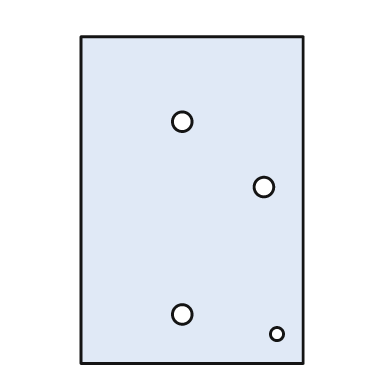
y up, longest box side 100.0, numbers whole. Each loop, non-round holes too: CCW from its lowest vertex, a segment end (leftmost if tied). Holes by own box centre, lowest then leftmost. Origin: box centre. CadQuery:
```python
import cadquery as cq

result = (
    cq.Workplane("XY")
    .moveTo(-34.0, -50.0)
    .lineTo(34.0, -50.0)
    .lineTo(34.0, 50.0)
    .lineTo(-34.0, 50.0)
    .close()
    .moveTo(26.0, -41.0)
    .circle(2.0)
    .moveTo(-3.0, -35.0)
    .circle(3.0)
    .moveTo(22.0, 4.0)
    .circle(3.0)
    .moveTo(-3.0, 24.0)
    .circle(3.0)
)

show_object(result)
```